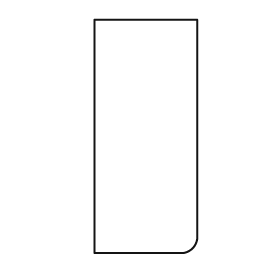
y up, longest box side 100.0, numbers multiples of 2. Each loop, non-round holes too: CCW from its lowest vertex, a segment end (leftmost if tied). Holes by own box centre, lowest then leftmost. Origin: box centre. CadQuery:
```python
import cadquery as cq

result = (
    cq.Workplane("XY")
    .moveTo(-22.0, -50.0)
    .lineTo(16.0, -50.0)
    .threePointArc((20.0, -48.0), (22.0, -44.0))
    .lineTo(22.0, 50.0)
    .lineTo(-22.0, 50.0)
    .close()
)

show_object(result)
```